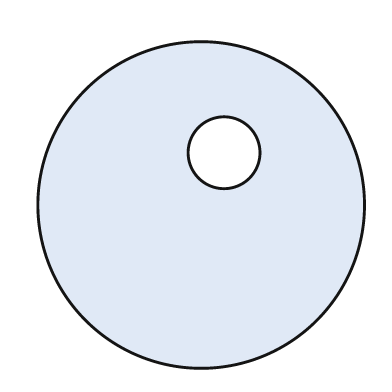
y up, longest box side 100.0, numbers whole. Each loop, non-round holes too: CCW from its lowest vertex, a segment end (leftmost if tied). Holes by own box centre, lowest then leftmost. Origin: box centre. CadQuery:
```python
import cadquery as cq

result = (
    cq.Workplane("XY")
    .moveTo(0.0, 0.0)
    .circle(50.0)
    .moveTo(7.0, 16.0)
    .circle(11.0)
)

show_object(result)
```